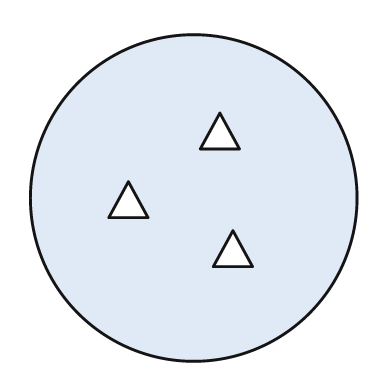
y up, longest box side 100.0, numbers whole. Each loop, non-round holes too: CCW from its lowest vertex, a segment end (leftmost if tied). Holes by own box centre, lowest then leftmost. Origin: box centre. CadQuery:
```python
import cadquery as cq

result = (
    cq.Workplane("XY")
    .moveTo(0.0, 0.0)
    .circle(50.0)
    .moveTo(6.0, -21.0)
    .lineTo(18.0, -21.0)
    .lineTo(12.0, -10.0)
    .close()
    .moveTo(-26.0, -6.0)
    .lineTo(-14.0, -6.0)
    .lineTo(-20.0, 5.0)
    .close()
    .moveTo(2.0, 15.0)
    .lineTo(14.0, 15.0)
    .lineTo(8.0, 26.0)
    .close()
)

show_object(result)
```